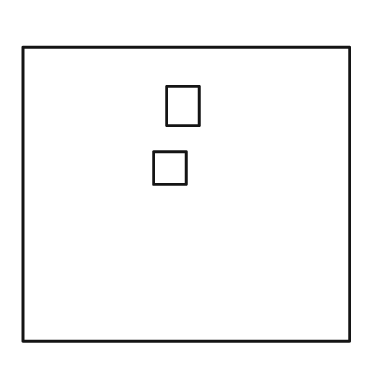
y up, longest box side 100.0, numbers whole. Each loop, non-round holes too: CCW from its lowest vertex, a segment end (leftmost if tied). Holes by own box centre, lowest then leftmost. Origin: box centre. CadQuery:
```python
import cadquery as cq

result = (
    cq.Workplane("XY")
    .moveTo(-50.0, -45.0)
    .lineTo(50.0, -45.0)
    .lineTo(50.0, 45.0)
    .lineTo(-50.0, 45.0)
    .close()
    .moveTo(-10.0, 3.0)
    .lineTo(0.0, 3.0)
    .lineTo(0.0, 13.0)
    .lineTo(-10.0, 13.0)
    .close()
    .moveTo(-6.0, 21.0)
    .lineTo(4.0, 21.0)
    .lineTo(4.0, 33.0)
    .lineTo(-6.0, 33.0)
    .close()
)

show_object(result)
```